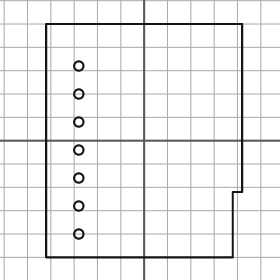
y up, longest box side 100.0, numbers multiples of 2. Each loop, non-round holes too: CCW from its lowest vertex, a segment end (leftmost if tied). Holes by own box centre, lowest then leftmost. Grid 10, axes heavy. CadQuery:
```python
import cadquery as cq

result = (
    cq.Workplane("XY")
    .moveTo(-42.0, -50.0)
    .lineTo(38.0, -50.0)
    .lineTo(38.0, -22.0)
    .lineTo(42.0, -22.0)
    .lineTo(42.0, 50.0)
    .lineTo(-42.0, 50.0)
    .close()
    .moveTo(-28.0, -40.0)
    .circle(2.0)
    .moveTo(-28.0, -28.0)
    .circle(2.0)
    .moveTo(-28.0, -16.0)
    .circle(2.0)
    .moveTo(-28.0, -4.0)
    .circle(2.0)
    .moveTo(-28.0, 8.0)
    .circle(2.0)
    .moveTo(-28.0, 20.0)
    .circle(2.0)
    .moveTo(-28.0, 32.0)
    .circle(2.0)
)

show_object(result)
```